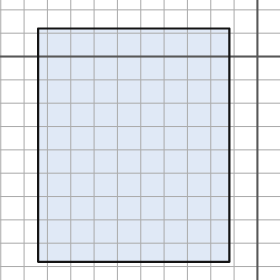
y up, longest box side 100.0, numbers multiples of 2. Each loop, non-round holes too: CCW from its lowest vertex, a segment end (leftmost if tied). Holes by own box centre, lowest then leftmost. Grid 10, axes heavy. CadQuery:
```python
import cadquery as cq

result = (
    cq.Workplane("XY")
    .moveTo(-94.0, -88.0)
    .lineTo(-12.0, -88.0)
    .lineTo(-12.0, 12.0)
    .lineTo(-94.0, 12.0)
    .close()
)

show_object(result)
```